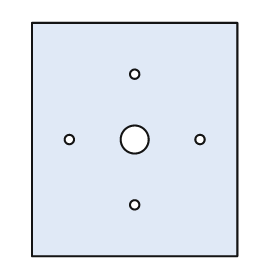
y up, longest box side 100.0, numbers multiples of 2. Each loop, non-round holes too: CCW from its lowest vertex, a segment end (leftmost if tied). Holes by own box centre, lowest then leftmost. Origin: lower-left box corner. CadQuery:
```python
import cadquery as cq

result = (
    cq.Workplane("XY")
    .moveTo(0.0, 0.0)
    .lineTo(88.0, 0.0)
    .lineTo(88.0, 100.0)
    .lineTo(0.0, 100.0)
    .close()
    .moveTo(44.0, 22.0)
    .circle(2.0)
    .moveTo(16.0, 50.0)
    .circle(2.0)
    .moveTo(44.0, 50.0)
    .circle(6.0)
    .moveTo(72.0, 50.0)
    .circle(2.0)
    .moveTo(44.0, 78.0)
    .circle(2.0)
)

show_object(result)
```